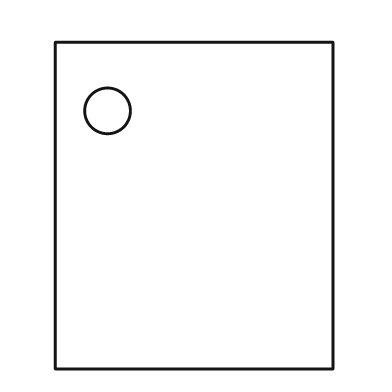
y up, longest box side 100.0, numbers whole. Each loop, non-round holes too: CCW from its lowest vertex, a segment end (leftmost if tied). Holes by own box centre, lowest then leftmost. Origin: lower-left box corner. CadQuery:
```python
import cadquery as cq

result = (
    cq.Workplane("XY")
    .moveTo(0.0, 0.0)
    .lineTo(85.0, 0.0)
    .lineTo(85.0, 100.0)
    .lineTo(0.0, 100.0)
    .close()
    .moveTo(16.0, 79.0)
    .circle(7.0)
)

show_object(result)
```